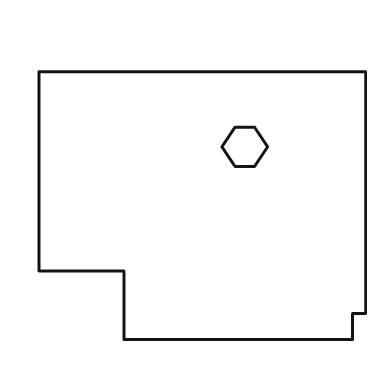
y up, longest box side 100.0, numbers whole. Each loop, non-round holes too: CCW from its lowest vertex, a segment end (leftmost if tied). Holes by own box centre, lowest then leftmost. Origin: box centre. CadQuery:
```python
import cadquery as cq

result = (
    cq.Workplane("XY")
    .moveTo(-24.0, -41.0)
    .lineTo(46.0, -41.0)
    .lineTo(46.0, -33.0)
    .lineTo(50.0, -33.0)
    .lineTo(50.0, 41.0)
    .lineTo(-50.0, 41.0)
    .lineTo(-50.0, -20.0)
    .lineTo(-24.0, -20.0)
    .close()
    .moveTo(10.0, 12.0)
    .lineTo(16.0, 12.0)
    .lineTo(20.0, 18.0)
    .lineTo(16.0, 24.0)
    .lineTo(10.0, 24.0)
    .lineTo(6.0, 18.0)
    .close()
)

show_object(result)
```